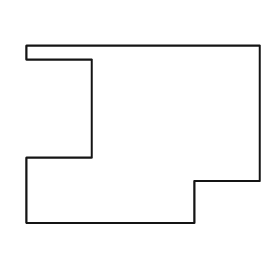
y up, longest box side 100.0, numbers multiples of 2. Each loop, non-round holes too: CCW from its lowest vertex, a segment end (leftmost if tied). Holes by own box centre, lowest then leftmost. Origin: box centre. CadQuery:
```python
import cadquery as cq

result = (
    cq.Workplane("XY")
    .moveTo(-50.0, -38.0)
    .lineTo(22.0, -38.0)
    .lineTo(22.0, -20.0)
    .lineTo(50.0, -20.0)
    .lineTo(50.0, 38.0)
    .lineTo(-50.0, 38.0)
    .lineTo(-50.0, 32.0)
    .lineTo(-22.0, 32.0)
    .lineTo(-22.0, -10.0)
    .lineTo(-50.0, -10.0)
    .close()
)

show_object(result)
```